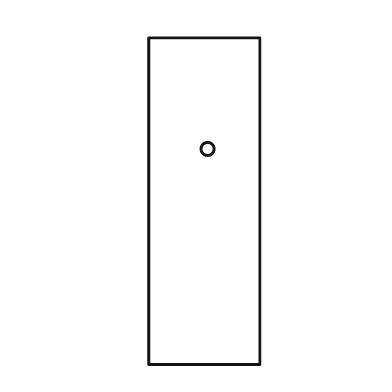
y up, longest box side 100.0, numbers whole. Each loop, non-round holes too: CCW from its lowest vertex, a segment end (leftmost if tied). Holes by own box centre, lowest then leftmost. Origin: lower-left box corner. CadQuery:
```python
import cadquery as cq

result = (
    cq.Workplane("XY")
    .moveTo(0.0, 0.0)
    .lineTo(34.0, 0.0)
    .lineTo(34.0, 100.0)
    .lineTo(0.0, 100.0)
    .close()
    .moveTo(18.0, 66.0)
    .circle(2.0)
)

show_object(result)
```